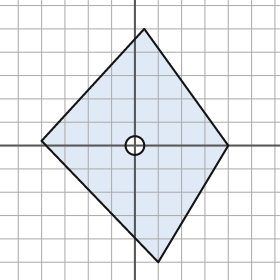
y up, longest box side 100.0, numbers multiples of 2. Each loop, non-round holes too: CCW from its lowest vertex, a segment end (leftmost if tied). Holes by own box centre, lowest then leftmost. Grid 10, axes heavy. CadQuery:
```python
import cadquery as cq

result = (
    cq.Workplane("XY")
    .moveTo(10.0, -50.0)
    .lineTo(40.0, 0.0)
    .lineTo(4.0, 50.0)
    .lineTo(-40.0, 2.0)
    .close()
    .moveTo(0.0, 0.0)
    .circle(4.0)
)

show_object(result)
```